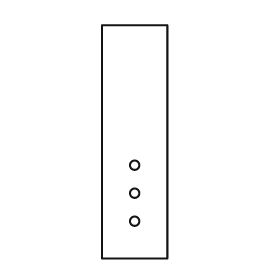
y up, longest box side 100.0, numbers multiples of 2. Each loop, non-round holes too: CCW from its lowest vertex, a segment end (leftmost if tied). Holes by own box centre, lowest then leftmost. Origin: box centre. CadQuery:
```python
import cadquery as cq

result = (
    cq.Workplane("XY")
    .moveTo(-14.0, -50.0)
    .lineTo(14.0, -50.0)
    .lineTo(14.0, 50.0)
    .lineTo(-14.0, 50.0)
    .close()
    .moveTo(0.0, -34.0)
    .circle(2.0)
    .moveTo(0.0, -22.0)
    .circle(2.0)
    .moveTo(0.0, -10.0)
    .circle(2.0)
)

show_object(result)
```